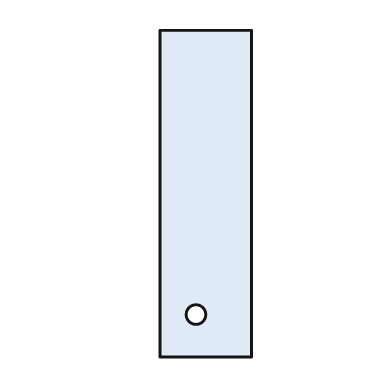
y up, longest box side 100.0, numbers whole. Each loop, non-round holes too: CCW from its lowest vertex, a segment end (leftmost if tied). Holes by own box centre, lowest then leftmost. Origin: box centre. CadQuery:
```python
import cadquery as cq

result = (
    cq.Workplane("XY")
    .moveTo(-14.0, -50.0)
    .lineTo(14.0, -50.0)
    .lineTo(14.0, 50.0)
    .lineTo(-14.0, 50.0)
    .close()
    .moveTo(-3.0, -37.0)
    .circle(3.0)
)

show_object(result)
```